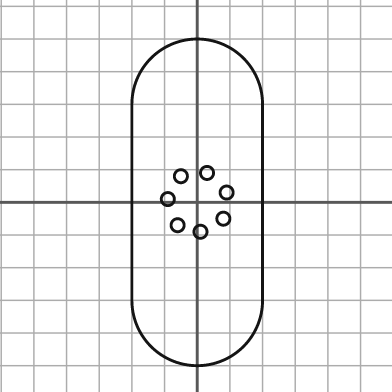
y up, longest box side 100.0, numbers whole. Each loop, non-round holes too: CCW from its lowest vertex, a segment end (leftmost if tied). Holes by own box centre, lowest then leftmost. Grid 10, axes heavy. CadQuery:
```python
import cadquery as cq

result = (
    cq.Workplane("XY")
    .moveTo(-20.0, -30.0)
    .threePointArc((0.0, -50.0), (20.0, -30.0))
    .lineTo(20.0, 30.0)
    .threePointArc((0.0, 50.0), (-20.0, 30.0))
    .close()
    .moveTo(1.0, -9.0)
    .circle(2.0)
    .moveTo(-6.0, -7.0)
    .circle(2.0)
    .moveTo(8.0, -5.0)
    .circle(2.0)
    .moveTo(-9.0, 1.0)
    .circle(2.0)
    .moveTo(9.0, 3.0)
    .circle(2.0)
    .moveTo(-5.0, 8.0)
    .circle(2.0)
    .moveTo(3.0, 9.0)
    .circle(2.0)
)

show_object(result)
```